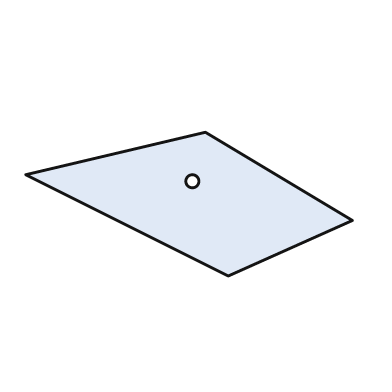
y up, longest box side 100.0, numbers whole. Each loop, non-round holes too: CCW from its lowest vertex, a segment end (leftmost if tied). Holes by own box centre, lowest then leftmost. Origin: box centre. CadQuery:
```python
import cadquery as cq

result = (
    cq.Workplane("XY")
    .moveTo(12.0, -22.0)
    .lineTo(50.0, -5.0)
    .lineTo(5.0, 22.0)
    .lineTo(-50.0, 9.0)
    .close()
    .moveTo(1.0, 7.0)
    .circle(2.0)
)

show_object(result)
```